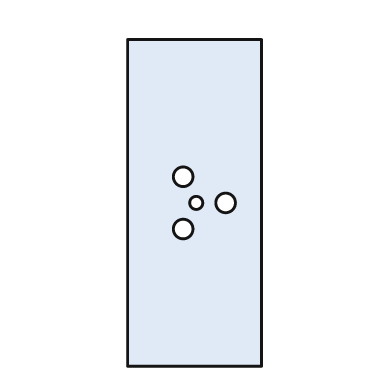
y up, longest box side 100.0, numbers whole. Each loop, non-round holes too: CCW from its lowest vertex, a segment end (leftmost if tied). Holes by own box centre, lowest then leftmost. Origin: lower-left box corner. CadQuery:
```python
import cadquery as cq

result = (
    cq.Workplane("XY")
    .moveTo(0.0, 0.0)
    .lineTo(41.0, 0.0)
    .lineTo(41.0, 100.0)
    .lineTo(0.0, 100.0)
    .close()
    .moveTo(17.0, 42.0)
    .circle(3.0)
    .moveTo(21.0, 50.0)
    .circle(2.0)
    .moveTo(30.0, 50.0)
    .circle(3.0)
    .moveTo(17.0, 58.0)
    .circle(3.0)
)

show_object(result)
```